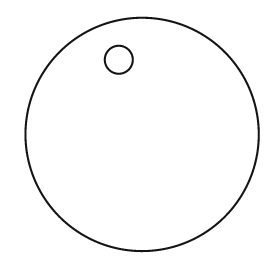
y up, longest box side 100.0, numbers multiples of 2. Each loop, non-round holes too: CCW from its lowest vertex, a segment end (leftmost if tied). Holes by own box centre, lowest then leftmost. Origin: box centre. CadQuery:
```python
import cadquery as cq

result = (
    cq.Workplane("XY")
    .moveTo(0.0, 0.0)
    .circle(50.0)
    .moveTo(-10.0, 32.0)
    .circle(6.0)
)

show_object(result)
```